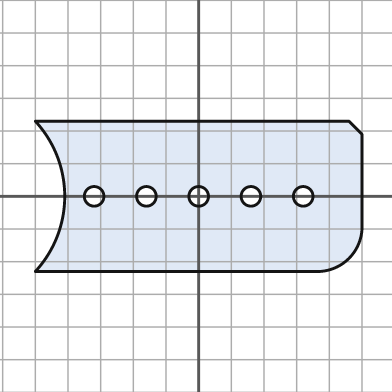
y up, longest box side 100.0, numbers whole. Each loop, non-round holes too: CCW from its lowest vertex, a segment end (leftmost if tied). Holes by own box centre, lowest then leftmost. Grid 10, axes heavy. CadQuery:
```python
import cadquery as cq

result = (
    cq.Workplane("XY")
    .moveTo(-50.0, -23.0)
    .lineTo(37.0, -23.0)
    .threePointArc((46.0, -19.0), (50.0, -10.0))
    .lineTo(50.0, 19.0)
    .lineTo(46.0, 23.0)
    .lineTo(-50.0, 23.0)
    .threePointArc((-41.0, 0.0), (-50.0, -23.0))
    .close()
    .moveTo(-32.0, 0.0)
    .circle(3.0)
    .moveTo(-16.0, 0.0)
    .circle(3.0)
    .moveTo(0.0, 0.0)
    .circle(3.0)
    .moveTo(16.0, 0.0)
    .circle(3.0)
    .moveTo(32.0, 0.0)
    .circle(3.0)
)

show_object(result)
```